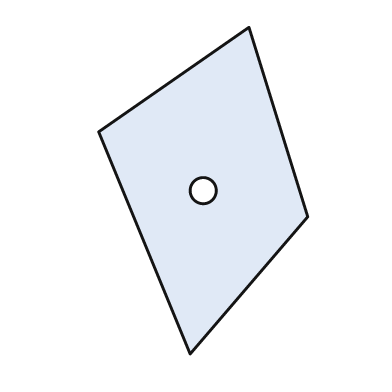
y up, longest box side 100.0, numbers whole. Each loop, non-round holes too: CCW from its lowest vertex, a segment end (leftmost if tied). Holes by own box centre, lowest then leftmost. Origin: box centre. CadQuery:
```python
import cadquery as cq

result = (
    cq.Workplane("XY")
    .moveTo(-4.0, -50.0)
    .lineTo(32.0, -8.0)
    .lineTo(14.0, 50.0)
    .lineTo(-32.0, 18.0)
    .close()
    .moveTo(0.0, 0.0)
    .circle(4.0)
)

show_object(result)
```